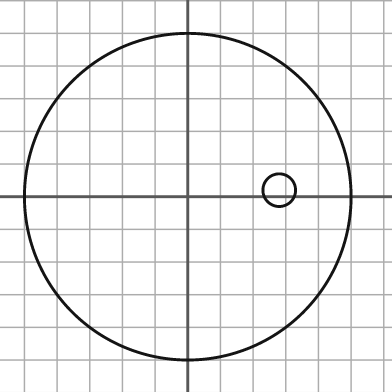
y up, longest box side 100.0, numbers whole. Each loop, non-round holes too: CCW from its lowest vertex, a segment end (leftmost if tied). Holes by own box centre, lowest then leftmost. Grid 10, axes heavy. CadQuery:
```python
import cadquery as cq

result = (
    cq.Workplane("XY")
    .moveTo(0.0, 0.0)
    .circle(50.0)
    .moveTo(28.0, 2.0)
    .circle(5.0)
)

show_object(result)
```